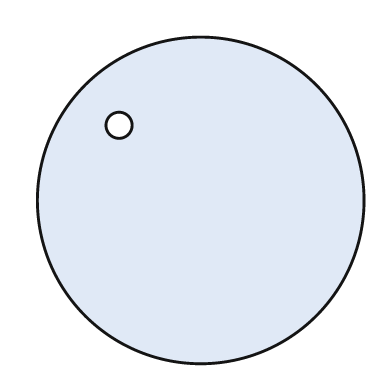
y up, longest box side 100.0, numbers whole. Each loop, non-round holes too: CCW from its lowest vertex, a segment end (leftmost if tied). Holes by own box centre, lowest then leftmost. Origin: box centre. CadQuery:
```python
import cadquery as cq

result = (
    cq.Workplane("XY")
    .moveTo(0.0, 0.0)
    .circle(50.0)
    .moveTo(-25.0, 23.0)
    .circle(4.0)
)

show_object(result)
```